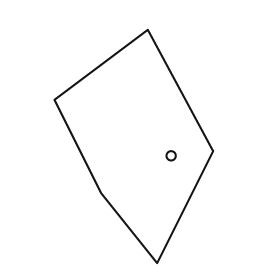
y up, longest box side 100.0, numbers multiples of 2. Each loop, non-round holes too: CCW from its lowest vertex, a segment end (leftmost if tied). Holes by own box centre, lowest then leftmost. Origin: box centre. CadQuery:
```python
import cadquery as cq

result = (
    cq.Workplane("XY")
    .moveTo(10.0, -50.0)
    .lineTo(34.0, -2.0)
    .lineTo(6.0, 50.0)
    .lineTo(-34.0, 20.0)
    .lineTo(-14.0, -20.0)
    .close()
    .moveTo(16.0, -4.0)
    .circle(2.0)
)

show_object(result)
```